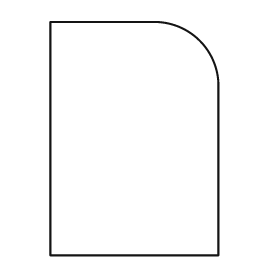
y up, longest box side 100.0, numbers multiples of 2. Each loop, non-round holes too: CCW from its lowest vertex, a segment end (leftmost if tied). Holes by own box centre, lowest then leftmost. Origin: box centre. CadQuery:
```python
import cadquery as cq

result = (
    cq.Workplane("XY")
    .moveTo(-36.0, -50.0)
    .lineTo(36.0, -50.0)
    .lineTo(36.0, 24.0)
    .threePointArc((28.0, 42.0), (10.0, 50.0))
    .lineTo(-36.0, 50.0)
    .close()
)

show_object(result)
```